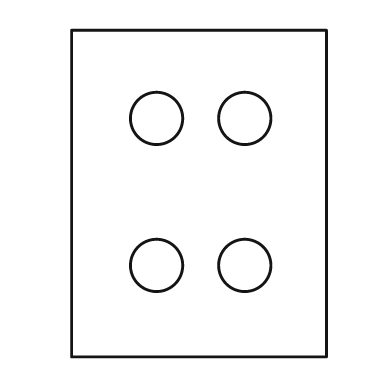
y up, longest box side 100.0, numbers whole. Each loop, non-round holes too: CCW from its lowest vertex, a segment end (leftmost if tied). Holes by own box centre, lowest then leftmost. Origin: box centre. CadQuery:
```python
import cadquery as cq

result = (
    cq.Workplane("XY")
    .moveTo(-39.0, -50.0)
    .lineTo(39.0, -50.0)
    .lineTo(39.0, 50.0)
    .lineTo(-39.0, 50.0)
    .close()
    .moveTo(-13.0, -22.0)
    .circle(8.0)
    .moveTo(14.0, -22.0)
    .circle(8.0)
    .moveTo(-13.0, 23.0)
    .circle(8.0)
    .moveTo(14.0, 23.0)
    .circle(8.0)
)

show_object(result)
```